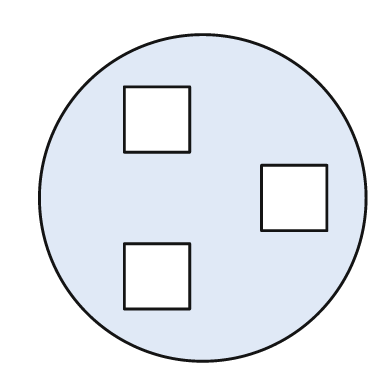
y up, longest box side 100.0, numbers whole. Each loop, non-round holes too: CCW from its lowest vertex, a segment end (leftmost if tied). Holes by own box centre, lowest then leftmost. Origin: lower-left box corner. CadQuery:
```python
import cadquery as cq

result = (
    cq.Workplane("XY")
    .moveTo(50.0, 50.0)
    .circle(50.0)
    .moveTo(26.0, 16.0)
    .lineTo(46.0, 16.0)
    .lineTo(46.0, 36.0)
    .lineTo(26.0, 36.0)
    .close()
    .moveTo(68.0, 40.0)
    .lineTo(88.0, 40.0)
    .lineTo(88.0, 60.0)
    .lineTo(68.0, 60.0)
    .close()
    .moveTo(26.0, 64.0)
    .lineTo(46.0, 64.0)
    .lineTo(46.0, 84.0)
    .lineTo(26.0, 84.0)
    .close()
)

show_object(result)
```